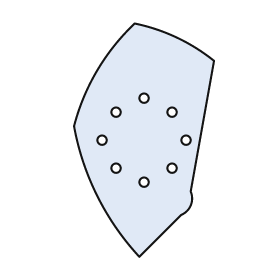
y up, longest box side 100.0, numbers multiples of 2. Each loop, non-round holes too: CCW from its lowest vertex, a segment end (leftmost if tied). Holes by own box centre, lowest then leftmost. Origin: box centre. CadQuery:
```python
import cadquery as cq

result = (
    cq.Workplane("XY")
    .moveTo(-2.0, -50.0)
    .lineTo(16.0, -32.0)
    .threePointArc((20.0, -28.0), (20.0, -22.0))
    .lineTo(30.0, 34.0)
    .threePointArc((14.0, 44.0), (-4.0, 50.0))
    .threePointArc((-20.0, 30.0), (-30.0, 6.0))
    .threePointArc((-20.0, -24.0), (-2.0, -50.0))
    .close()
    .moveTo(0.0, -18.0)
    .circle(2.0)
    .moveTo(-12.0, -12.0)
    .circle(2.0)
    .moveTo(12.0, -12.0)
    .circle(2.0)
    .moveTo(-18.0, 0.0)
    .circle(2.0)
    .moveTo(18.0, 0.0)
    .circle(2.0)
    .moveTo(-12.0, 12.0)
    .circle(2.0)
    .moveTo(12.0, 12.0)
    .circle(2.0)
    .moveTo(0.0, 18.0)
    .circle(2.0)
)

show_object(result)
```